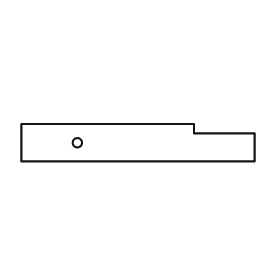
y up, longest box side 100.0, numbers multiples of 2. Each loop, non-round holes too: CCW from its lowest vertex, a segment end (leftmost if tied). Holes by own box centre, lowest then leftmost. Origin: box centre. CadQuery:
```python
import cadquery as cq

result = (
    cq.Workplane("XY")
    .moveTo(-50.0, -8.0)
    .lineTo(50.0, -8.0)
    .lineTo(50.0, 4.0)
    .lineTo(24.0, 4.0)
    .lineTo(24.0, 8.0)
    .lineTo(-50.0, 8.0)
    .close()
    .moveTo(-26.0, 0.0)
    .circle(2.0)
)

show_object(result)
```